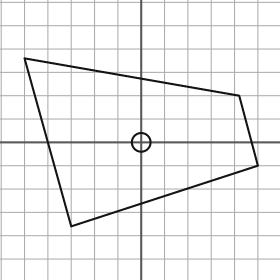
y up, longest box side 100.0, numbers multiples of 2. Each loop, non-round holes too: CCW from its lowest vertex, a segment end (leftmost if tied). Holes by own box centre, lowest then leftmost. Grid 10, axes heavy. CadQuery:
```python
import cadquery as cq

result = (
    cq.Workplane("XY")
    .moveTo(-30.0, -36.0)
    .lineTo(50.0, -10.0)
    .lineTo(42.0, 20.0)
    .lineTo(-50.0, 36.0)
    .close()
    .moveTo(0.0, 0.0)
    .circle(4.0)
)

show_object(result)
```